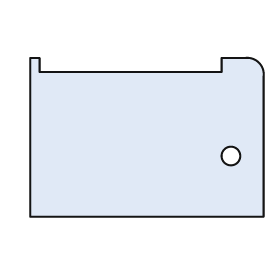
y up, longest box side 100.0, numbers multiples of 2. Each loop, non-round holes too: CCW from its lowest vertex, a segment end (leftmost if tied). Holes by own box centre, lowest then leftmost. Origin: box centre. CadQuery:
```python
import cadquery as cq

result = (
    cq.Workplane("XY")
    .moveTo(-50.0, -34.0)
    .lineTo(50.0, -34.0)
    .lineTo(50.0, 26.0)
    .threePointArc((48.0, 32.0), (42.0, 34.0))
    .lineTo(32.0, 34.0)
    .lineTo(32.0, 28.0)
    .lineTo(-46.0, 28.0)
    .lineTo(-46.0, 34.0)
    .lineTo(-50.0, 34.0)
    .close()
    .moveTo(36.0, -8.0)
    .circle(4.0)
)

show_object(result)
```